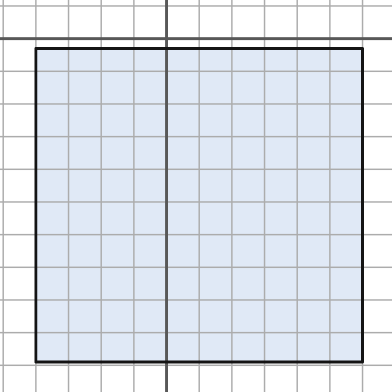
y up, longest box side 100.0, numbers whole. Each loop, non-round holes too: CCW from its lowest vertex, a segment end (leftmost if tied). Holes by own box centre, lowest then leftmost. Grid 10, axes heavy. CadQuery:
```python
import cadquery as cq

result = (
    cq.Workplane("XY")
    .moveTo(-40.0, -99.0)
    .lineTo(60.0, -99.0)
    .lineTo(60.0, -3.0)
    .lineTo(-40.0, -3.0)
    .close()
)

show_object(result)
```